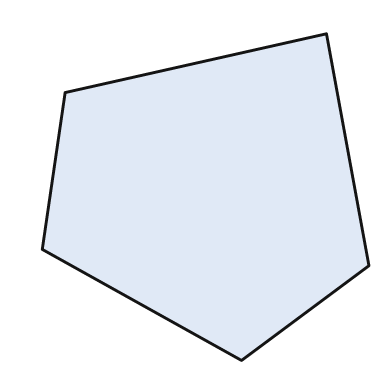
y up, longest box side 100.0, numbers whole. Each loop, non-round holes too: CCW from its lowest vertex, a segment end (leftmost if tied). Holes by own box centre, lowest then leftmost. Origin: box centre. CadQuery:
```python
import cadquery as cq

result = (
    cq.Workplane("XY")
    .moveTo(11.0, -50.0)
    .lineTo(50.0, -21.0)
    .lineTo(37.0, 50.0)
    .lineTo(-43.0, 32.0)
    .lineTo(-50.0, -16.0)
    .close()
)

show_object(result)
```